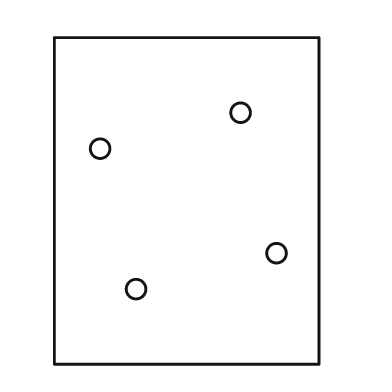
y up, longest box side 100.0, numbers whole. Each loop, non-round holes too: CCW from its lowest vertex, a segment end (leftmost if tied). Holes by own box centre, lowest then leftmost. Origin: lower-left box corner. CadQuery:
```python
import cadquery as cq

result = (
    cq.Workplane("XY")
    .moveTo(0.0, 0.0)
    .lineTo(81.0, 0.0)
    .lineTo(81.0, 100.0)
    .lineTo(0.0, 100.0)
    .close()
    .moveTo(25.0, 23.0)
    .circle(3.0)
    .moveTo(68.0, 34.0)
    .circle(3.0)
    .moveTo(14.0, 66.0)
    .circle(3.0)
    .moveTo(57.0, 77.0)
    .circle(3.0)
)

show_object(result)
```